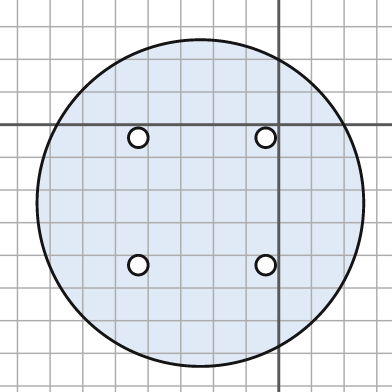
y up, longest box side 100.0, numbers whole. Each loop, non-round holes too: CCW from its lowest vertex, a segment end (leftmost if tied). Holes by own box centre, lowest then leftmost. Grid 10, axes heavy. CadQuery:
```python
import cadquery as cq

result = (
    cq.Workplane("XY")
    .moveTo(-24.0, -24.0)
    .circle(50.0)
    .moveTo(-43.0, -43.0)
    .circle(3.0)
    .moveTo(-4.0, -43.0)
    .circle(3.0)
    .moveTo(-43.0, -4.0)
    .circle(3.0)
    .moveTo(-4.0, -4.0)
    .circle(3.0)
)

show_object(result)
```